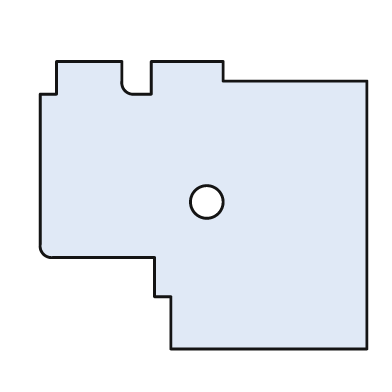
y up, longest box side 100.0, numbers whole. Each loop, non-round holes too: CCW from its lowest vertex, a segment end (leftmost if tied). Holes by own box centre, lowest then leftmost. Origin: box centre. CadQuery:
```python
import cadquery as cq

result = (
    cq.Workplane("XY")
    .moveTo(-10.0, -44.0)
    .lineTo(50.0, -44.0)
    .lineTo(50.0, 38.0)
    .lineTo(6.0, 38.0)
    .lineTo(6.0, 44.0)
    .lineTo(-16.0, 44.0)
    .lineTo(-16.0, 34.0)
    .lineTo(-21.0, 34.0)
    .threePointArc((-24.0, 35.0), (-25.0, 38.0))
    .lineTo(-25.0, 44.0)
    .lineTo(-45.0, 44.0)
    .lineTo(-45.0, 34.0)
    .lineTo(-50.0, 34.0)
    .lineTo(-50.0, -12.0)
    .threePointArc((-49.0, -15.0), (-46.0, -16.0))
    .lineTo(-15.0, -16.0)
    .lineTo(-15.0, -28.0)
    .lineTo(-10.0, -28.0)
    .close()
    .moveTo(1.0, 1.0)
    .circle(5.0)
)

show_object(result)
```